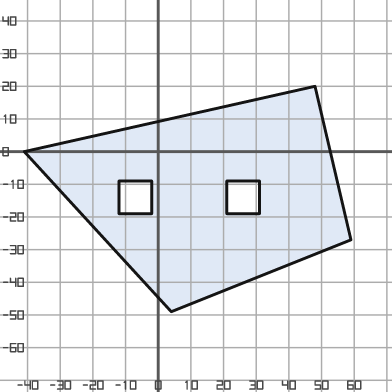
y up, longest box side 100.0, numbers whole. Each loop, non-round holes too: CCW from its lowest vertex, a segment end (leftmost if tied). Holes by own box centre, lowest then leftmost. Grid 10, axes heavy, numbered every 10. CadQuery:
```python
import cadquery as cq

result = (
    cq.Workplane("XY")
    .moveTo(4.0, -49.0)
    .lineTo(59.0, -27.0)
    .lineTo(48.0, 20.0)
    .lineTo(-41.0, 0.0)
    .close()
    .moveTo(-12.0, -19.0)
    .lineTo(-2.0, -19.0)
    .lineTo(-2.0, -9.0)
    .lineTo(-12.0, -9.0)
    .close()
    .moveTo(21.0, -19.0)
    .lineTo(31.0, -19.0)
    .lineTo(31.0, -9.0)
    .lineTo(21.0, -9.0)
    .close()
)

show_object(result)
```